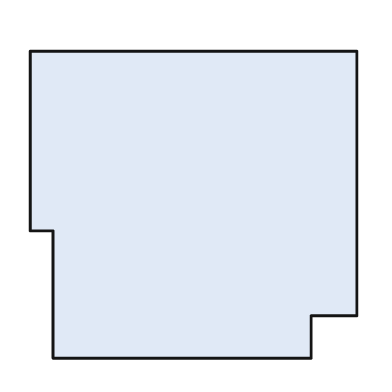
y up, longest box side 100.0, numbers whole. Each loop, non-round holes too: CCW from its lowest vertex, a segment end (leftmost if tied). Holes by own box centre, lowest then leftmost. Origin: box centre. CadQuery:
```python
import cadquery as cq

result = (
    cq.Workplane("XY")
    .moveTo(-43.0, -47.0)
    .lineTo(36.0, -47.0)
    .lineTo(36.0, -34.0)
    .lineTo(50.0, -34.0)
    .lineTo(50.0, 47.0)
    .lineTo(-50.0, 47.0)
    .lineTo(-50.0, -8.0)
    .lineTo(-43.0, -8.0)
    .close()
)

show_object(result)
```